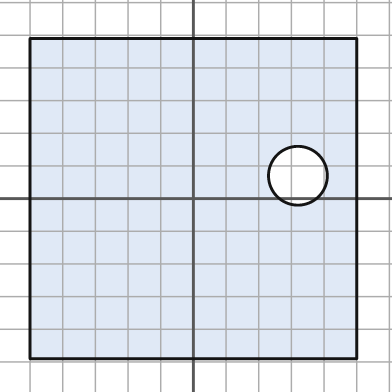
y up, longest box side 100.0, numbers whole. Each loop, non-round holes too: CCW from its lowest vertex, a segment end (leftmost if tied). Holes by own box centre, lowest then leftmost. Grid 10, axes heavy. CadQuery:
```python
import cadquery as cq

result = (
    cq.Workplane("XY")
    .moveTo(-50.0, -49.0)
    .lineTo(50.0, -49.0)
    .lineTo(50.0, 49.0)
    .lineTo(-50.0, 49.0)
    .close()
    .moveTo(32.0, 7.0)
    .circle(9.0)
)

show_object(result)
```